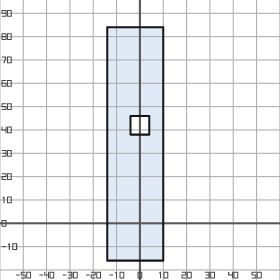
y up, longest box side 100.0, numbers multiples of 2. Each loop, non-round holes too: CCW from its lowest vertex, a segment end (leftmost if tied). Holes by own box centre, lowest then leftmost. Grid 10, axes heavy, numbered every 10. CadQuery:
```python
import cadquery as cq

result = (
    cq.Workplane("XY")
    .moveTo(-14.0, -16.0)
    .lineTo(10.0, -16.0)
    .lineTo(10.0, 84.0)
    .lineTo(-14.0, 84.0)
    .close()
    .moveTo(-4.0, 38.0)
    .lineTo(4.0, 38.0)
    .lineTo(4.0, 46.0)
    .lineTo(-4.0, 46.0)
    .close()
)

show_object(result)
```